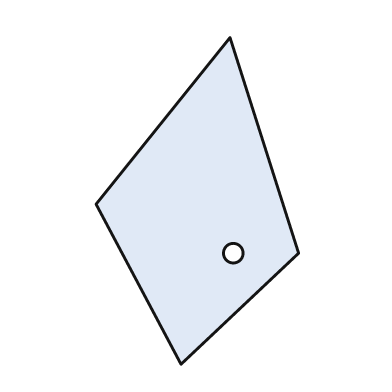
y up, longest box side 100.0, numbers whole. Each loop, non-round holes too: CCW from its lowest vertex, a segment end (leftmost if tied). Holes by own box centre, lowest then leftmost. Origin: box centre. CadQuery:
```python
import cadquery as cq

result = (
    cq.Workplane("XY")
    .moveTo(-5.0, -50.0)
    .lineTo(31.0, -16.0)
    .lineTo(10.0, 50.0)
    .lineTo(-31.0, -1.0)
    .close()
    .moveTo(11.0, -16.0)
    .circle(3.0)
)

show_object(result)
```